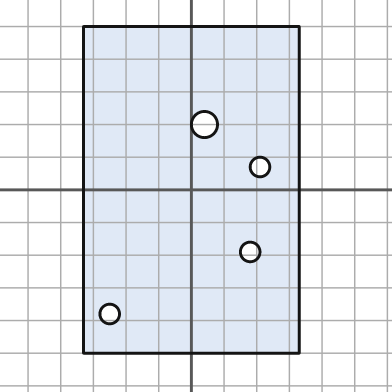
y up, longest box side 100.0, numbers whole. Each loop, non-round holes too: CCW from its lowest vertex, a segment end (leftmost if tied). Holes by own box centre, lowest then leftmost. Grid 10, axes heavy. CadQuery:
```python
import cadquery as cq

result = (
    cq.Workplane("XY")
    .moveTo(-33.0, -50.0)
    .lineTo(33.0, -50.0)
    .lineTo(33.0, 50.0)
    .lineTo(-33.0, 50.0)
    .close()
    .moveTo(-25.0, -38.0)
    .circle(3.0)
    .moveTo(18.0, -19.0)
    .circle(3.0)
    .moveTo(21.0, 7.0)
    .circle(3.0)
    .moveTo(4.0, 20.0)
    .circle(4.0)
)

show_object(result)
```